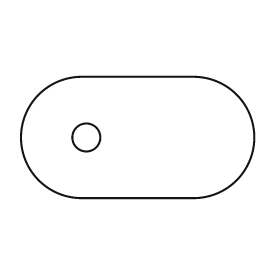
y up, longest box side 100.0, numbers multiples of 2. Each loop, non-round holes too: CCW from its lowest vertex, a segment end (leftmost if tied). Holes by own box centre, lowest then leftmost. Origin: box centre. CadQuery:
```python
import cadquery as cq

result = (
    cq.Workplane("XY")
    .moveTo(-24.0, -26.0)
    .lineTo(24.0, -26.0)
    .threePointArc((50.0, 0.0), (24.0, 26.0))
    .lineTo(-24.0, 26.0)
    .threePointArc((-50.0, 0.0), (-24.0, -26.0))
    .close()
    .moveTo(-22.0, 0.0)
    .circle(6.0)
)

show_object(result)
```